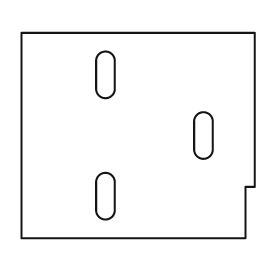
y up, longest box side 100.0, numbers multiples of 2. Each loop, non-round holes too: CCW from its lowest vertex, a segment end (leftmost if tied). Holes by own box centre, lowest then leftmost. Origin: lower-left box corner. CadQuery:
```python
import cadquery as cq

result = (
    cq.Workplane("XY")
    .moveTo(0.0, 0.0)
    .lineTo(96.0, 0.0)
    .lineTo(96.0, 22.0)
    .lineTo(100.0, 22.0)
    .lineTo(100.0, 88.0)
    .lineTo(0.0, 88.0)
    .close()
    .moveTo(32.0, 12.0)
    .threePointArc((36.0, 8.0), (40.0, 12.0))
    .lineTo(40.0, 24.0)
    .threePointArc((36.0, 28.0), (32.0, 24.0))
    .close()
    .moveTo(74.0, 38.0)
    .threePointArc((78.0, 34.0), (82.0, 38.0))
    .lineTo(82.0, 50.0)
    .threePointArc((78.0, 54.0), (74.0, 50.0))
    .close()
    .moveTo(32.0, 64.0)
    .threePointArc((36.0, 60.0), (40.0, 64.0))
    .lineTo(40.0, 76.0)
    .threePointArc((36.0, 80.0), (32.0, 76.0))
    .close()
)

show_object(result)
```